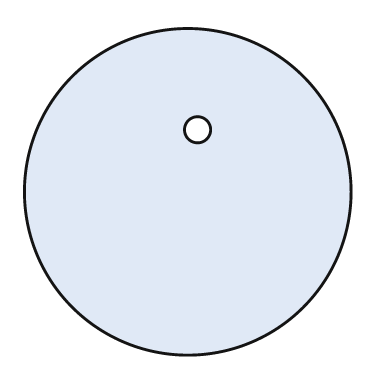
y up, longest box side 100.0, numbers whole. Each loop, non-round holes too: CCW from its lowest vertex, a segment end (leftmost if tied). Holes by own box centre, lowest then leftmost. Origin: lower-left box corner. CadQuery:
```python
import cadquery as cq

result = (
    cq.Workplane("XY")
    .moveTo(50.0, 50.0)
    .circle(50.0)
    .moveTo(53.0, 69.0)
    .circle(4.0)
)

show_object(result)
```